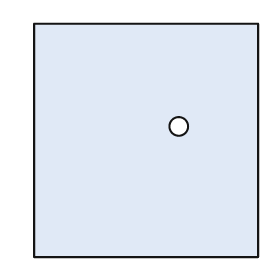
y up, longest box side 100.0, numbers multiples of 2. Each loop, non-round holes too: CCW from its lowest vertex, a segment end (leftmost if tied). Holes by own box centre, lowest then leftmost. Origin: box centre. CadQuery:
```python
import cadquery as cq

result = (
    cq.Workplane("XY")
    .moveTo(-48.0, -50.0)
    .lineTo(48.0, -50.0)
    .lineTo(48.0, 50.0)
    .lineTo(-48.0, 50.0)
    .close()
    .moveTo(14.0, 6.0)
    .circle(4.0)
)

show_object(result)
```